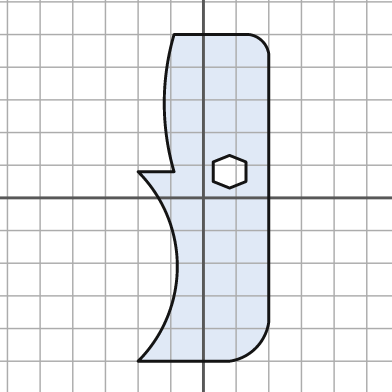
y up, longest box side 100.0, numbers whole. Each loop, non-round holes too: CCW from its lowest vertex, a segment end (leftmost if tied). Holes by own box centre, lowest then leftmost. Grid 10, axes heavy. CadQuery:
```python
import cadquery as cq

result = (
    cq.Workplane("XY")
    .moveTo(-20.0, -50.0)
    .lineTo(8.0, -50.0)
    .threePointArc((16.0, -46.0), (20.0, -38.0))
    .lineTo(20.0, 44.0)
    .threePointArc((18.0, 48.0), (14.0, 50.0))
    .lineTo(-9.0, 50.0)
    .threePointArc((-12.0, 29.0), (-9.0, 8.0))
    .lineTo(-20.0, 8.0)
    .threePointArc((-8.0, -21.0), (-20.0, -50.0))
    .close()
    .moveTo(8.0, 3.0)
    .lineTo(13.0, 5.0)
    .lineTo(13.0, 11.0)
    .lineTo(8.0, 13.0)
    .lineTo(3.0, 11.0)
    .lineTo(3.0, 5.0)
    .close()
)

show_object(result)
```